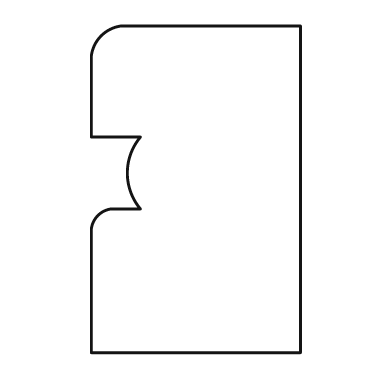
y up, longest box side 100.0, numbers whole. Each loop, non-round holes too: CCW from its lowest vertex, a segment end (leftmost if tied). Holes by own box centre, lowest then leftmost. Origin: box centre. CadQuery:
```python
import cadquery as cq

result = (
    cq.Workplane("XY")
    .moveTo(-32.0, -50.0)
    .lineTo(32.0, -50.0)
    .lineTo(32.0, 50.0)
    .lineTo(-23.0, 50.0)
    .threePointArc((-29.0, 47.0), (-32.0, 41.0))
    .lineTo(-32.0, 16.0)
    .lineTo(-17.0, 16.0)
    .threePointArc((-21.0, 5.0), (-17.0, -6.0))
    .lineTo(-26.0, -6.0)
    .threePointArc((-30.0, -8.0), (-32.0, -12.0))
    .close()
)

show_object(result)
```